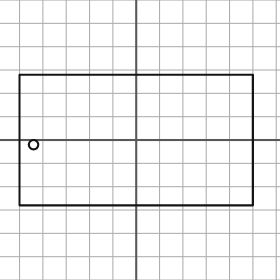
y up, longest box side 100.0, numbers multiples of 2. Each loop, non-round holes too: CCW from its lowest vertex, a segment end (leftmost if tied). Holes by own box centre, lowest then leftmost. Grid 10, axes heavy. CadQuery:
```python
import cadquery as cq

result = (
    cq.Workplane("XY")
    .moveTo(-50.0, -28.0)
    .lineTo(50.0, -28.0)
    .lineTo(50.0, 28.0)
    .lineTo(-50.0, 28.0)
    .close()
    .moveTo(-44.0, -2.0)
    .circle(2.0)
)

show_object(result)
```